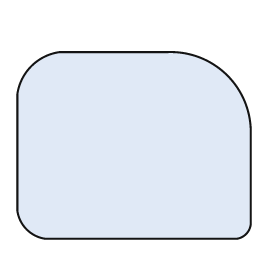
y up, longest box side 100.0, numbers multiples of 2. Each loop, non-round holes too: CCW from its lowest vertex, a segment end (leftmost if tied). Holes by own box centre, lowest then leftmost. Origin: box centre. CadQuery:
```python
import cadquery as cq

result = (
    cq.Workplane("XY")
    .moveTo(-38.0, -40.0)
    .lineTo(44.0, -40.0)
    .threePointArc((48.0, -38.0), (50.0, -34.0))
    .lineTo(50.0, 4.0)
    .threePointArc((40.0, 30.0), (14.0, 40.0))
    .lineTo(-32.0, 40.0)
    .threePointArc((-44.0, 34.0), (-50.0, 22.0))
    .lineTo(-50.0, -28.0)
    .threePointArc((-46.0, -36.0), (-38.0, -40.0))
    .close()
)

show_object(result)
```